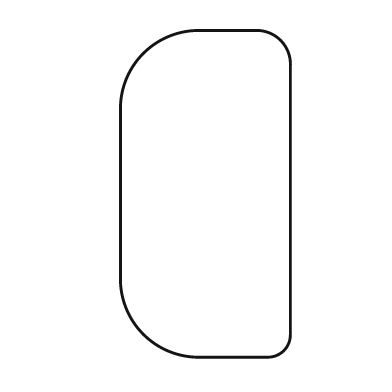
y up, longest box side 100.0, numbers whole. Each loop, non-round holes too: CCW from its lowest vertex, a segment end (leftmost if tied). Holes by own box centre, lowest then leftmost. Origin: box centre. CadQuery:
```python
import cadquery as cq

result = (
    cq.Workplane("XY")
    .moveTo(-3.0, -50.0)
    .lineTo(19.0, -50.0)
    .threePointArc((24.0, -48.0), (26.0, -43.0))
    .lineTo(26.0, 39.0)
    .threePointArc((23.0, 47.0), (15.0, 50.0))
    .lineTo(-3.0, 50.0)
    .threePointArc((-19.0, 43.0), (-26.0, 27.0))
    .lineTo(-26.0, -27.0)
    .threePointArc((-19.0, -43.0), (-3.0, -50.0))
    .close()
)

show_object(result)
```